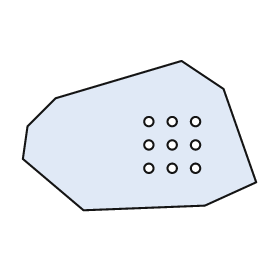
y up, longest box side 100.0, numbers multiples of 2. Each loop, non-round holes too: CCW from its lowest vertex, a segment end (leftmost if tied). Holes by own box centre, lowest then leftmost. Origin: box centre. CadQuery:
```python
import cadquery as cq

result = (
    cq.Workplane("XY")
    .moveTo(-24.0, -32.0)
    .lineTo(28.0, -30.0)
    .lineTo(50.0, -20.0)
    .lineTo(36.0, 20.0)
    .lineTo(18.0, 32.0)
    .lineTo(-36.0, 16.0)
    .lineTo(-48.0, 4.0)
    .lineTo(-50.0, -10.0)
    .close()
    .moveTo(4.0, -14.0)
    .circle(2.0)
    .moveTo(14.0, -14.0)
    .circle(2.0)
    .moveTo(24.0, -14.0)
    .circle(2.0)
    .moveTo(4.0, -4.0)
    .circle(2.0)
    .moveTo(14.0, -4.0)
    .circle(2.0)
    .moveTo(24.0, -4.0)
    .circle(2.0)
    .moveTo(4.0, 6.0)
    .circle(2.0)
    .moveTo(14.0, 6.0)
    .circle(2.0)
    .moveTo(24.0, 6.0)
    .circle(2.0)
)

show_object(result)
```